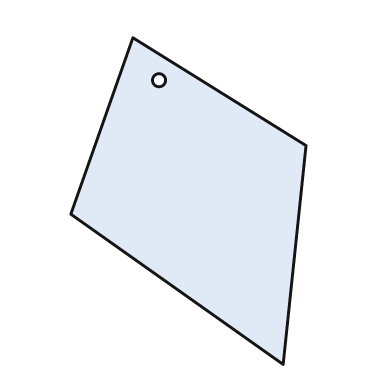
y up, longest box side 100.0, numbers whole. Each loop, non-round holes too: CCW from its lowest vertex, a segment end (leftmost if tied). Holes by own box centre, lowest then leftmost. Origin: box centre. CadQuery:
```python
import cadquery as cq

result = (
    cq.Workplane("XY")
    .moveTo(29.0, -50.0)
    .lineTo(36.0, 17.0)
    .lineTo(-17.0, 50.0)
    .lineTo(-36.0, -4.0)
    .close()
    .moveTo(-9.0, 37.0)
    .circle(2.0)
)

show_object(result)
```